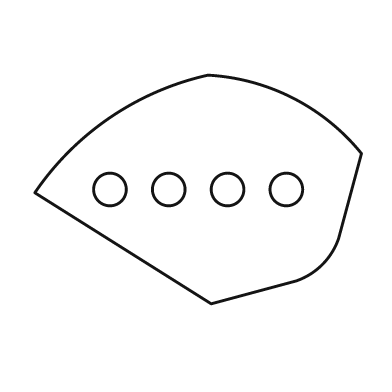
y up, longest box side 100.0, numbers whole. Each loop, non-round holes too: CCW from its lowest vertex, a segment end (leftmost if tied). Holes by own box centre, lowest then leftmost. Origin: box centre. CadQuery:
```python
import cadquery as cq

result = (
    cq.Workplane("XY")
    .moveTo(4.0, -35.0)
    .lineTo(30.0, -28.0)
    .threePointArc((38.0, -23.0), (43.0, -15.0))
    .lineTo(50.0, 11.0)
    .threePointArc((29.0, 28.0), (3.0, 35.0))
    .threePointArc((-27.0, 22.0), (-50.0, -1.0))
    .close()
    .moveTo(-27.0, 0.0)
    .circle(5.0)
    .moveTo(-9.0, 0.0)
    .circle(5.0)
    .moveTo(9.0, 0.0)
    .circle(5.0)
    .moveTo(27.0, 0.0)
    .circle(5.0)
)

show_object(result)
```